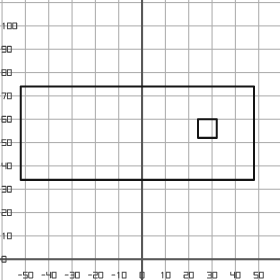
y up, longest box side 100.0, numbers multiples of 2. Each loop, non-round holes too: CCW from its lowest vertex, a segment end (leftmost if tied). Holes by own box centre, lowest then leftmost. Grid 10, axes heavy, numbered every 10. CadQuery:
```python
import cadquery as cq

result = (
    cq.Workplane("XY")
    .moveTo(-52.0, 34.0)
    .lineTo(48.0, 34.0)
    .lineTo(48.0, 74.0)
    .lineTo(-52.0, 74.0)
    .close()
    .moveTo(24.0, 52.0)
    .lineTo(32.0, 52.0)
    .lineTo(32.0, 60.0)
    .lineTo(24.0, 60.0)
    .close()
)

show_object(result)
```